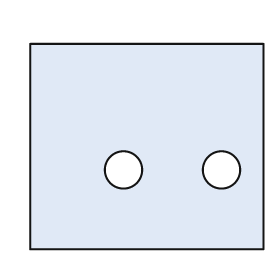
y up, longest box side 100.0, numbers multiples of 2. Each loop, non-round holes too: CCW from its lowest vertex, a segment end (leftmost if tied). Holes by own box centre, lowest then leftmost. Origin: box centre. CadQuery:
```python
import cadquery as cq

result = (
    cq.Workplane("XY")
    .moveTo(-50.0, -44.0)
    .lineTo(50.0, -44.0)
    .lineTo(50.0, 44.0)
    .lineTo(-50.0, 44.0)
    .close()
    .moveTo(-10.0, -10.0)
    .circle(8.0)
    .moveTo(32.0, -10.0)
    .circle(8.0)
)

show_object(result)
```